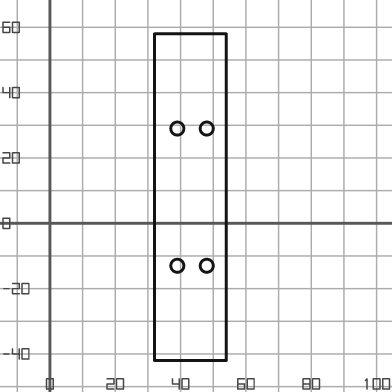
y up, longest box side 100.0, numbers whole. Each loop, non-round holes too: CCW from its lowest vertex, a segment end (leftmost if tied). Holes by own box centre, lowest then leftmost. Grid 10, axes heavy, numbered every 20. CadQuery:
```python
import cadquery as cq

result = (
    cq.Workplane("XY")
    .moveTo(32.0, -42.0)
    .lineTo(54.0, -42.0)
    .lineTo(54.0, 58.0)
    .lineTo(32.0, 58.0)
    .close()
    .moveTo(39.0, -13.0)
    .circle(2.0)
    .moveTo(48.0, -13.0)
    .circle(2.0)
    .moveTo(39.0, 29.0)
    .circle(2.0)
    .moveTo(48.0, 29.0)
    .circle(2.0)
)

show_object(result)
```